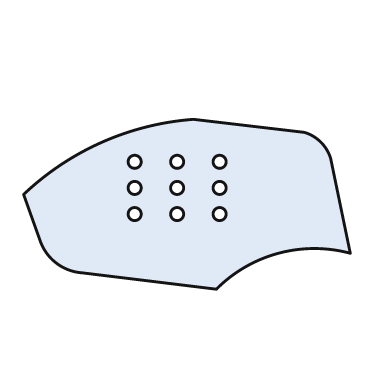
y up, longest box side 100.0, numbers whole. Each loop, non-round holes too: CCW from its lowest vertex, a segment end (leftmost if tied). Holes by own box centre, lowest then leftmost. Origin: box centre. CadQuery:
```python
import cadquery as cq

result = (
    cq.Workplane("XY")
    .moveTo(9.0, -26.0)
    .threePointArc((28.0, -15.0), (50.0, -15.0))
    .lineTo(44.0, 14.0)
    .threePointArc((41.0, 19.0), (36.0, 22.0))
    .lineTo(2.0, 26.0)
    .threePointArc((-26.0, 19.0), (-50.0, 3.0))
    .lineTo(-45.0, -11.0)
    .threePointArc((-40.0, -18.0), (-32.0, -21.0))
    .close()
    .moveTo(-16.0, -3.0)
    .circle(2.0)
    .moveTo(-3.0, -3.0)
    .circle(2.0)
    .moveTo(10.0, -3.0)
    .circle(2.0)
    .moveTo(-16.0, 5.0)
    .circle(2.0)
    .moveTo(-3.0, 5.0)
    .circle(2.0)
    .moveTo(10.0, 5.0)
    .circle(2.0)
    .moveTo(-16.0, 13.0)
    .circle(2.0)
    .moveTo(-3.0, 13.0)
    .circle(2.0)
    .moveTo(10.0, 13.0)
    .circle(2.0)
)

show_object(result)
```